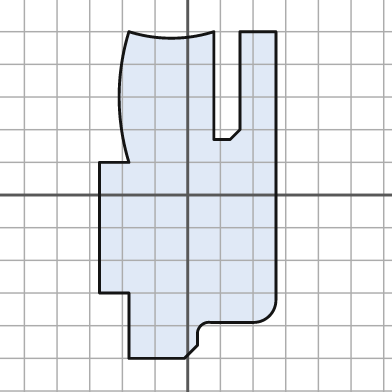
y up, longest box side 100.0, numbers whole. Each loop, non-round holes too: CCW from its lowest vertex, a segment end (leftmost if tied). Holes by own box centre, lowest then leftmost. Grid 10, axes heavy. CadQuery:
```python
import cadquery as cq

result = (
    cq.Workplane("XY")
    .moveTo(-18.0, -50.0)
    .lineTo(-1.0, -50.0)
    .lineTo(3.0, -46.0)
    .lineTo(3.0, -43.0)
    .threePointArc((4.0, -40.0), (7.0, -39.0))
    .lineTo(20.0, -39.0)
    .threePointArc((25.0, -37.0), (27.0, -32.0))
    .lineTo(27.0, 50.0)
    .lineTo(16.0, 50.0)
    .lineTo(16.0, 20.0)
    .lineTo(13.0, 17.0)
    .lineTo(8.0, 17.0)
    .lineTo(8.0, 50.0)
    .threePointArc((-5.0, 48.0), (-18.0, 50.0))
    .threePointArc((-21.0, 30.0), (-18.0, 10.0))
    .lineTo(-27.0, 10.0)
    .lineTo(-27.0, -30.0)
    .lineTo(-18.0, -30.0)
    .close()
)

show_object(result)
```